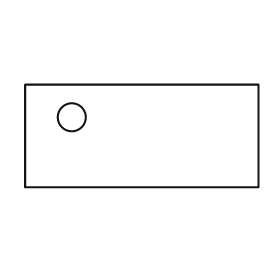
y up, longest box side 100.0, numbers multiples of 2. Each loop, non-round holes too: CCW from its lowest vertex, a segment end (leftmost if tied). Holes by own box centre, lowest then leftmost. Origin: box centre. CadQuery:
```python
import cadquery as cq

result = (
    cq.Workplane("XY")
    .moveTo(-50.0, -22.0)
    .lineTo(50.0, -22.0)
    .lineTo(50.0, 22.0)
    .lineTo(-50.0, 22.0)
    .close()
    .moveTo(-30.0, 8.0)
    .circle(6.0)
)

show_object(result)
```